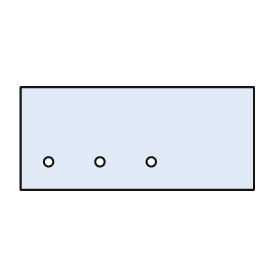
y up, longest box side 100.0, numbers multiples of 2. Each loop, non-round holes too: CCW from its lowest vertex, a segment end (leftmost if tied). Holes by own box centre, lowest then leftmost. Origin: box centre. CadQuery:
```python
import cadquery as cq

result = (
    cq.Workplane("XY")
    .moveTo(-50.0, -22.0)
    .lineTo(50.0, -22.0)
    .lineTo(50.0, 22.0)
    .lineTo(-50.0, 22.0)
    .close()
    .moveTo(-38.0, -10.0)
    .circle(2.0)
    .moveTo(-16.0, -10.0)
    .circle(2.0)
    .moveTo(6.0, -10.0)
    .circle(2.0)
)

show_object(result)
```